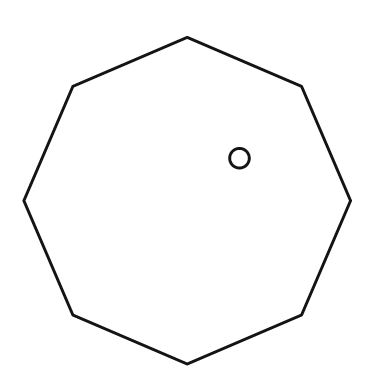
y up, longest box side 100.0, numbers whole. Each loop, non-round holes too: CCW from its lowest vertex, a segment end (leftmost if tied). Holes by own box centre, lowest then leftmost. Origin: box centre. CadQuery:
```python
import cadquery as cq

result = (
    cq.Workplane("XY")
    .moveTo(0.0, -50.0)
    .lineTo(35.0, -35.0)
    .lineTo(50.0, 0.0)
    .lineTo(35.0, 35.0)
    .lineTo(0.0, 50.0)
    .lineTo(-35.0, 35.0)
    .lineTo(-50.0, 0.0)
    .lineTo(-35.0, -35.0)
    .close()
    .moveTo(16.0, 13.0)
    .circle(3.0)
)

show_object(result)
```